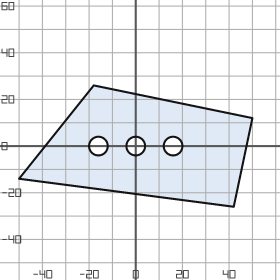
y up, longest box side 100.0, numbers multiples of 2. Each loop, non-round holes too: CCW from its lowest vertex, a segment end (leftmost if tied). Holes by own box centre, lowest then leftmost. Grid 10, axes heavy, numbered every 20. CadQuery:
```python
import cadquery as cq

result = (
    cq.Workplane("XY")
    .moveTo(42.0, -26.0)
    .lineTo(50.0, 12.0)
    .lineTo(-18.0, 26.0)
    .lineTo(-50.0, -14.0)
    .close()
    .moveTo(-16.0, 0.0)
    .circle(4.0)
    .moveTo(0.0, 0.0)
    .circle(4.0)
    .moveTo(16.0, 0.0)
    .circle(4.0)
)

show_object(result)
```